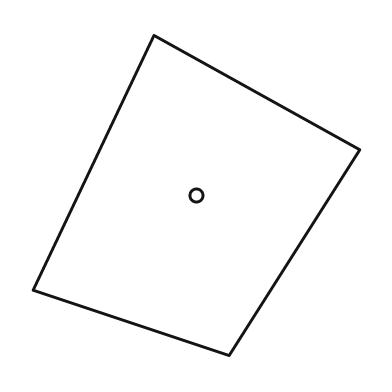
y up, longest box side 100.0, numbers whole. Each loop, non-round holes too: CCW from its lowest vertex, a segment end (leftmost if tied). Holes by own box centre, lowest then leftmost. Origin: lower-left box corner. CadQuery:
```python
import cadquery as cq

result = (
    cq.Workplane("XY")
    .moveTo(60.0, 0.0)
    .lineTo(100.0, 63.0)
    .lineTo(37.0, 98.0)
    .lineTo(0.0, 20.0)
    .close()
    .moveTo(50.0, 49.0)
    .circle(2.0)
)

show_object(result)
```